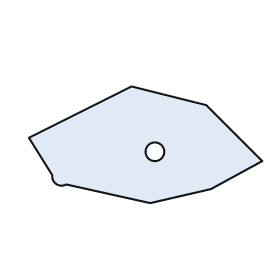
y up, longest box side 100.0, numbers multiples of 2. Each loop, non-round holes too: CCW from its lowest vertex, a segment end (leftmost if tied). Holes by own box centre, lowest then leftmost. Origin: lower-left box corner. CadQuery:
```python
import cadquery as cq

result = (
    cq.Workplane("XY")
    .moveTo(52.0, 0.0)
    .lineTo(78.0, 6.0)
    .lineTo(100.0, 18.0)
    .lineTo(76.0, 42.0)
    .lineTo(44.0, 50.0)
    .lineTo(0.0, 28.0)
    .lineTo(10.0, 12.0)
    .threePointArc((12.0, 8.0), (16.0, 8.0))
    .close()
    .moveTo(54.0, 22.0)
    .circle(4.0)
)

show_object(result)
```